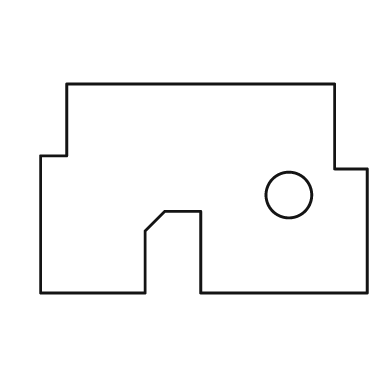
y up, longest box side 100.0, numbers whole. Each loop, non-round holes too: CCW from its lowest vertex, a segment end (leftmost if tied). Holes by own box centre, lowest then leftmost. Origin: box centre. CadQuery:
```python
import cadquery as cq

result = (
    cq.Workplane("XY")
    .moveTo(-50.0, -32.0)
    .lineTo(-18.0, -32.0)
    .lineTo(-18.0, -13.0)
    .lineTo(-12.0, -7.0)
    .lineTo(-1.0, -7.0)
    .lineTo(-1.0, -32.0)
    .lineTo(50.0, -32.0)
    .lineTo(50.0, 6.0)
    .lineTo(40.0, 6.0)
    .lineTo(40.0, 32.0)
    .lineTo(-42.0, 32.0)
    .lineTo(-42.0, 10.0)
    .lineTo(-50.0, 10.0)
    .close()
    .moveTo(26.0, -2.0)
    .circle(7.0)
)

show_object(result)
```